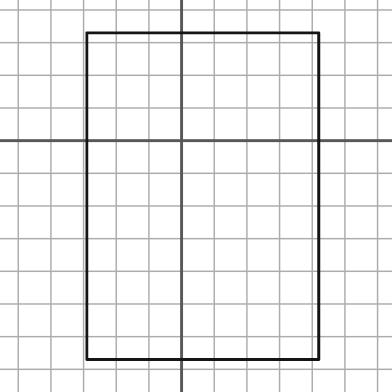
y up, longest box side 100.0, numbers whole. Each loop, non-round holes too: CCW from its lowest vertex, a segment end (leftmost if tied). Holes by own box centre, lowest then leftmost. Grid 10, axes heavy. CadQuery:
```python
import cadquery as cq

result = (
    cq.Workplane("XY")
    .moveTo(-29.0, -67.0)
    .lineTo(42.0, -67.0)
    .lineTo(42.0, 33.0)
    .lineTo(-29.0, 33.0)
    .close()
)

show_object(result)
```